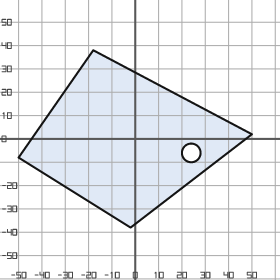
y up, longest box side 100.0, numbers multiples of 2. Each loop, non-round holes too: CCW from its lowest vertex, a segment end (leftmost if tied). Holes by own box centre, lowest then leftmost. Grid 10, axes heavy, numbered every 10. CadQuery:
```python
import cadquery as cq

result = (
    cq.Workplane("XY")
    .moveTo(-2.0, -38.0)
    .lineTo(50.0, 2.0)
    .lineTo(-18.0, 38.0)
    .lineTo(-50.0, -8.0)
    .close()
    .moveTo(24.0, -6.0)
    .circle(4.0)
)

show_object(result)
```